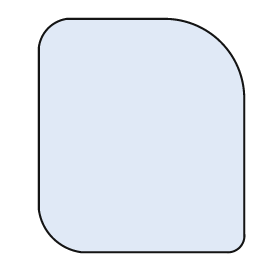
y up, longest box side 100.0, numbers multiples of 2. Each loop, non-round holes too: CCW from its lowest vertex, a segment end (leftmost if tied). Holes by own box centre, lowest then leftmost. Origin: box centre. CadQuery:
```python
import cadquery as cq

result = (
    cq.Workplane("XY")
    .moveTo(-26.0, -50.0)
    .lineTo(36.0, -50.0)
    .threePointArc((42.0, -48.0), (44.0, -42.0))
    .lineTo(44.0, 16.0)
    .threePointArc((34.0, 40.0), (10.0, 50.0))
    .lineTo(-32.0, 50.0)
    .threePointArc((-40.0, 46.0), (-44.0, 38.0))
    .lineTo(-44.0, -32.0)
    .threePointArc((-38.0, -44.0), (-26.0, -50.0))
    .close()
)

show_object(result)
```